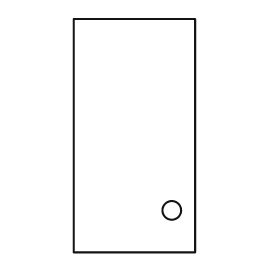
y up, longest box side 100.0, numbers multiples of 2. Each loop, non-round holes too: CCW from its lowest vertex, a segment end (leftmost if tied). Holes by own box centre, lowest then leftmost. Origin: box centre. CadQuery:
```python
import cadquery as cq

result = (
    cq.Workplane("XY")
    .moveTo(-26.0, -50.0)
    .lineTo(26.0, -50.0)
    .lineTo(26.0, 50.0)
    .lineTo(-26.0, 50.0)
    .close()
    .moveTo(16.0, -32.0)
    .circle(4.0)
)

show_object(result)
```